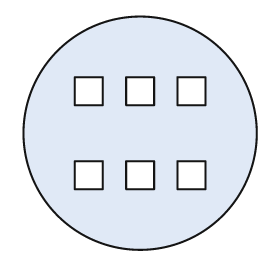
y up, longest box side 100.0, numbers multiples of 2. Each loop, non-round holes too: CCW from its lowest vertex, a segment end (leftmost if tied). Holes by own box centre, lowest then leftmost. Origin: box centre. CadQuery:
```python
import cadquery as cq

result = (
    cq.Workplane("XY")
    .moveTo(0.0, 0.0)
    .circle(50.0)
    .moveTo(-28.0, -24.0)
    .lineTo(-16.0, -24.0)
    .lineTo(-16.0, -12.0)
    .lineTo(-28.0, -12.0)
    .close()
    .moveTo(-6.0, -24.0)
    .lineTo(6.0, -24.0)
    .lineTo(6.0, -12.0)
    .lineTo(-6.0, -12.0)
    .close()
    .moveTo(16.0, -24.0)
    .lineTo(28.0, -24.0)
    .lineTo(28.0, -12.0)
    .lineTo(16.0, -12.0)
    .close()
    .moveTo(-28.0, 12.0)
    .lineTo(-16.0, 12.0)
    .lineTo(-16.0, 24.0)
    .lineTo(-28.0, 24.0)
    .close()
    .moveTo(-6.0, 12.0)
    .lineTo(6.0, 12.0)
    .lineTo(6.0, 24.0)
    .lineTo(-6.0, 24.0)
    .close()
    .moveTo(16.0, 12.0)
    .lineTo(28.0, 12.0)
    .lineTo(28.0, 24.0)
    .lineTo(16.0, 24.0)
    .close()
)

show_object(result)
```